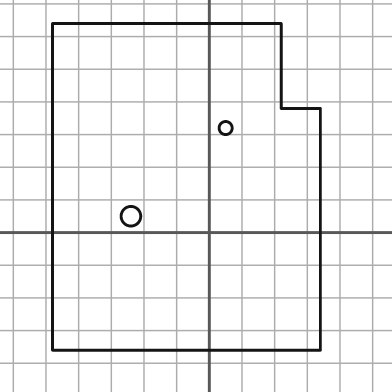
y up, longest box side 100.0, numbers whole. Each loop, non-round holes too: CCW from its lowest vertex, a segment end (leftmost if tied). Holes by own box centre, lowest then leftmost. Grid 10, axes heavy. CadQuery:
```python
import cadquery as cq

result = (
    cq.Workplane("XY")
    .moveTo(-48.0, -36.0)
    .lineTo(34.0, -36.0)
    .lineTo(34.0, 38.0)
    .lineTo(22.0, 38.0)
    .lineTo(22.0, 64.0)
    .lineTo(-48.0, 64.0)
    .close()
    .moveTo(-24.0, 5.0)
    .circle(3.0)
    .moveTo(5.0, 32.0)
    .circle(2.0)
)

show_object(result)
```